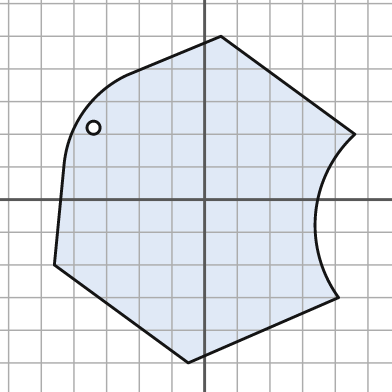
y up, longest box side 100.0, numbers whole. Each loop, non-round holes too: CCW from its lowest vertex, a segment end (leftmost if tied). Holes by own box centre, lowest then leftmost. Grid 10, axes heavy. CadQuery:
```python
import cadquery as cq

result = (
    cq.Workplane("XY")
    .moveTo(-5.0, -50.0)
    .lineTo(41.0, -30.0)
    .threePointArc((34.0, -4.0), (46.0, 20.0))
    .lineTo(5.0, 50.0)
    .lineTo(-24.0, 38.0)
    .threePointArc((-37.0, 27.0), (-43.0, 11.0))
    .lineTo(-46.0, -20.0)
    .close()
    .moveTo(-34.0, 22.0)
    .circle(2.0)
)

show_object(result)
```